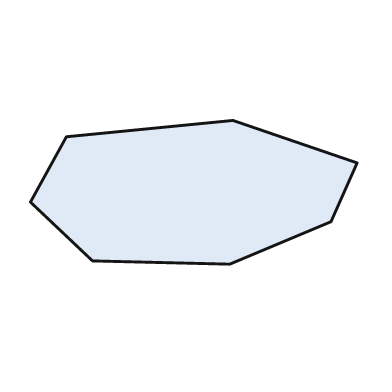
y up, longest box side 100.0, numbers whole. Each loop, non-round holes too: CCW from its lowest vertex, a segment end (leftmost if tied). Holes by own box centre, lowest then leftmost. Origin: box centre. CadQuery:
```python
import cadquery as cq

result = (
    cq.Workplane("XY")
    .moveTo(11.0, -22.0)
    .lineTo(42.0, -9.0)
    .lineTo(50.0, 9.0)
    .lineTo(12.0, 22.0)
    .lineTo(-39.0, 17.0)
    .lineTo(-50.0, -3.0)
    .lineTo(-31.0, -21.0)
    .close()
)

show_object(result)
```